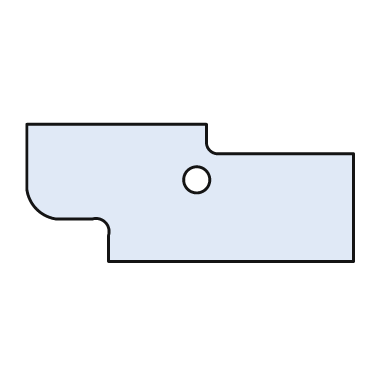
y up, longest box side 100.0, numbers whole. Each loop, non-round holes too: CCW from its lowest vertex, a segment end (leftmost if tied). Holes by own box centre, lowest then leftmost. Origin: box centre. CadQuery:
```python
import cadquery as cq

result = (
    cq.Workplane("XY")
    .moveTo(-25.0, -21.0)
    .lineTo(50.0, -21.0)
    .lineTo(50.0, 12.0)
    .lineTo(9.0, 12.0)
    .threePointArc((6.0, 13.0), (5.0, 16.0))
    .lineTo(5.0, 21.0)
    .lineTo(-50.0, 21.0)
    .lineTo(-50.0, 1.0)
    .threePointArc((-47.0, -5.0), (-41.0, -8.0))
    .lineTo(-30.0, -8.0)
    .threePointArc((-26.0, -9.0), (-25.0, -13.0))
    .close()
    .moveTo(2.0, 4.0)
    .circle(4.0)
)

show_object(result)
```